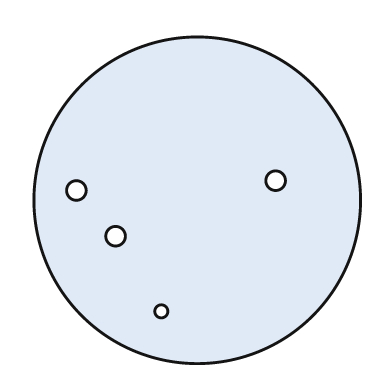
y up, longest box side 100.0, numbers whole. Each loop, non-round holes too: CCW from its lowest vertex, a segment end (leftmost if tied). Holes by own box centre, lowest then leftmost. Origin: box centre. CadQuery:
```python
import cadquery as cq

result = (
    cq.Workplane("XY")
    .moveTo(0.0, 0.0)
    .circle(50.0)
    .moveTo(-11.0, -34.0)
    .circle(2.0)
    .moveTo(-25.0, -11.0)
    .circle(3.0)
    .moveTo(-37.0, 3.0)
    .circle(3.0)
    .moveTo(24.0, 6.0)
    .circle(3.0)
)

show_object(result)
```